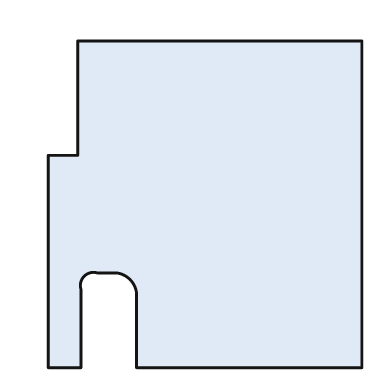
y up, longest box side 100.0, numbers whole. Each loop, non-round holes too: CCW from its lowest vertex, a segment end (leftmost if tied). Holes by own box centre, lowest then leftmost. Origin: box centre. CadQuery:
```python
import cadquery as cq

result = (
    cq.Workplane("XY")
    .moveTo(-48.0, -50.0)
    .lineTo(-38.0, -50.0)
    .lineTo(-38.0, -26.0)
    .threePointArc((-37.0, -22.0), (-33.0, -21.0))
    .lineTo(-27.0, -21.0)
    .threePointArc((-23.0, -23.0), (-21.0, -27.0))
    .lineTo(-21.0, -50.0)
    .lineTo(48.0, -50.0)
    .lineTo(48.0, 50.0)
    .lineTo(-39.0, 50.0)
    .lineTo(-39.0, 15.0)
    .lineTo(-48.0, 15.0)
    .close()
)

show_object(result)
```